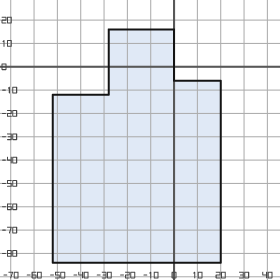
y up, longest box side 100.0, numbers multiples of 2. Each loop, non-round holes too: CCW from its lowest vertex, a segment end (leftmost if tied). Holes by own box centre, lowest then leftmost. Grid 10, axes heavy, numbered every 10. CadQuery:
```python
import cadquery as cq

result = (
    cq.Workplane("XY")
    .moveTo(-52.0, -84.0)
    .lineTo(20.0, -84.0)
    .lineTo(20.0, -6.0)
    .lineTo(0.0, -6.0)
    .lineTo(0.0, 16.0)
    .lineTo(-28.0, 16.0)
    .lineTo(-28.0, -12.0)
    .lineTo(-52.0, -12.0)
    .close()
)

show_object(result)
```